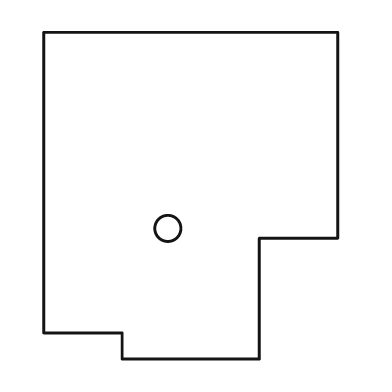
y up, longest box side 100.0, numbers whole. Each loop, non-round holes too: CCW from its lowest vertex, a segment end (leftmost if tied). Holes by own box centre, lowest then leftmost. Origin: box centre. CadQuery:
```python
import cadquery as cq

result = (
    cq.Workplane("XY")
    .moveTo(-21.0, -50.0)
    .lineTo(21.0, -50.0)
    .lineTo(21.0, -13.0)
    .lineTo(45.0, -13.0)
    .lineTo(45.0, 50.0)
    .lineTo(-45.0, 50.0)
    .lineTo(-45.0, -42.0)
    .lineTo(-21.0, -42.0)
    .close()
    .moveTo(-7.0, -10.0)
    .circle(4.0)
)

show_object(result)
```